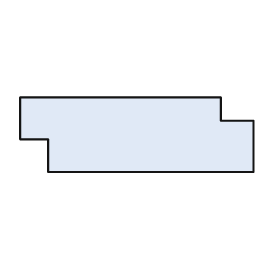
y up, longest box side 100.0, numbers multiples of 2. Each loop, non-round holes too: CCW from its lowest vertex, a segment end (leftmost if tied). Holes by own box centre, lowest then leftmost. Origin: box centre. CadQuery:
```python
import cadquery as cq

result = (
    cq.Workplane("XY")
    .moveTo(-38.0, -16.0)
    .lineTo(50.0, -16.0)
    .lineTo(50.0, 6.0)
    .lineTo(36.0, 6.0)
    .lineTo(36.0, 16.0)
    .lineTo(-50.0, 16.0)
    .lineTo(-50.0, -2.0)
    .lineTo(-38.0, -2.0)
    .close()
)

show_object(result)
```